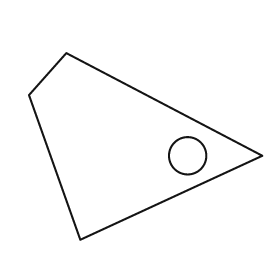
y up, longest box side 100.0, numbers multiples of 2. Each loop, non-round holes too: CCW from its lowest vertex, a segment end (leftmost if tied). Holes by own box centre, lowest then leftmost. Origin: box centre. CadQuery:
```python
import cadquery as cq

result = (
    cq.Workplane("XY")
    .moveTo(-28.0, -40.0)
    .lineTo(50.0, -4.0)
    .lineTo(-34.0, 40.0)
    .lineTo(-50.0, 22.0)
    .close()
    .moveTo(18.0, -4.0)
    .circle(8.0)
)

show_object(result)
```